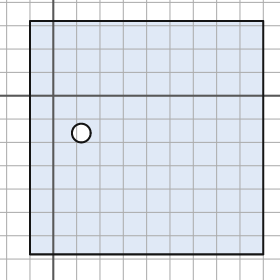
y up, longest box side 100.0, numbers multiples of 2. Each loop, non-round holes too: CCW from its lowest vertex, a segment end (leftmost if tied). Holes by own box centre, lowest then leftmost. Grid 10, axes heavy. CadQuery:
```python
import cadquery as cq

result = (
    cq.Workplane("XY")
    .moveTo(-10.0, -68.0)
    .lineTo(90.0, -68.0)
    .lineTo(90.0, 32.0)
    .lineTo(-10.0, 32.0)
    .close()
    .moveTo(12.0, -16.0)
    .circle(4.0)
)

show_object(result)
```